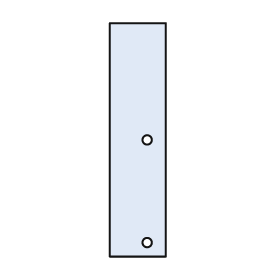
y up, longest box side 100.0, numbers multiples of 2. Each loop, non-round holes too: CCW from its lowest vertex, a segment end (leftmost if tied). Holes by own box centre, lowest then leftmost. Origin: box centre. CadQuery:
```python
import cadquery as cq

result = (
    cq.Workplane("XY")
    .moveTo(-12.0, -50.0)
    .lineTo(12.0, -50.0)
    .lineTo(12.0, 50.0)
    .lineTo(-12.0, 50.0)
    .close()
    .moveTo(4.0, -44.0)
    .circle(2.0)
    .moveTo(4.0, 0.0)
    .circle(2.0)
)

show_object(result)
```